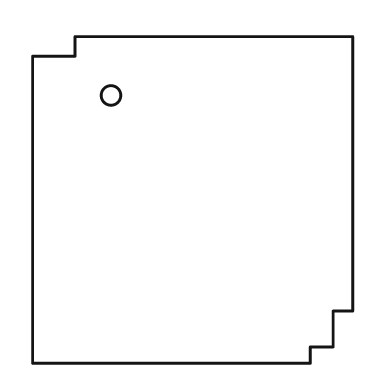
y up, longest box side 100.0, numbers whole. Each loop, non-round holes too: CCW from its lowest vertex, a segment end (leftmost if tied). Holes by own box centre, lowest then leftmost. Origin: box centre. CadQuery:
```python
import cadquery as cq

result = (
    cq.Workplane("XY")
    .moveTo(-49.0, -50.0)
    .lineTo(36.0, -50.0)
    .lineTo(36.0, -45.0)
    .lineTo(43.0, -45.0)
    .lineTo(43.0, -34.0)
    .lineTo(49.0, -34.0)
    .lineTo(49.0, 50.0)
    .lineTo(-36.0, 50.0)
    .lineTo(-36.0, 44.0)
    .lineTo(-49.0, 44.0)
    .close()
    .moveTo(-25.0, 32.0)
    .circle(3.0)
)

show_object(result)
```